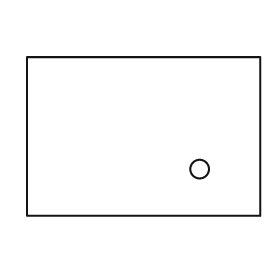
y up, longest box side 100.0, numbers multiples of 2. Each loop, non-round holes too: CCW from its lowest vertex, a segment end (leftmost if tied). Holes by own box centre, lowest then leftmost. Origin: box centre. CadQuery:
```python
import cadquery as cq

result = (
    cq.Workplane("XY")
    .moveTo(-50.0, -34.0)
    .lineTo(50.0, -34.0)
    .lineTo(50.0, 34.0)
    .lineTo(-50.0, 34.0)
    .close()
    .moveTo(24.0, -14.0)
    .circle(4.0)
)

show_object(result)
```